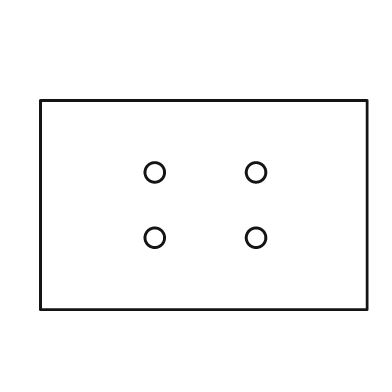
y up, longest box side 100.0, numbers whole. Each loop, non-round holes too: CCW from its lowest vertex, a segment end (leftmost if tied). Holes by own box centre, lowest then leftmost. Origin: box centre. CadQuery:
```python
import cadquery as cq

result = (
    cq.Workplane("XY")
    .moveTo(-50.0, -32.0)
    .lineTo(50.0, -32.0)
    .lineTo(50.0, 32.0)
    .lineTo(-50.0, 32.0)
    .close()
    .moveTo(-15.0, -10.0)
    .circle(3.0)
    .moveTo(16.0, -10.0)
    .circle(3.0)
    .moveTo(-15.0, 10.0)
    .circle(3.0)
    .moveTo(16.0, 10.0)
    .circle(3.0)
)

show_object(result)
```